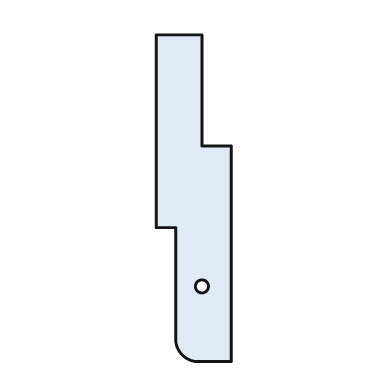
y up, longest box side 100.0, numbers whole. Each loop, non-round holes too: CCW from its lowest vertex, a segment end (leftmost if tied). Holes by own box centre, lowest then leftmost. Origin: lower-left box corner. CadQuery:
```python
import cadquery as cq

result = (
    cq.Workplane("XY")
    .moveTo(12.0, 0.0)
    .lineTo(23.0, 0.0)
    .lineTo(23.0, 66.0)
    .lineTo(14.0, 66.0)
    .lineTo(14.0, 100.0)
    .lineTo(0.0, 100.0)
    .lineTo(0.0, 41.0)
    .lineTo(6.0, 41.0)
    .lineTo(6.0, 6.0)
    .threePointArc((8.0, 2.0), (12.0, 0.0))
    .close()
    .moveTo(14.0, 23.0)
    .circle(2.0)
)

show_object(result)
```